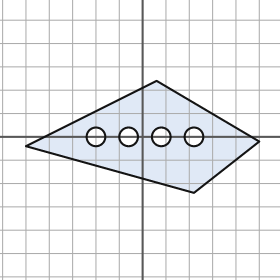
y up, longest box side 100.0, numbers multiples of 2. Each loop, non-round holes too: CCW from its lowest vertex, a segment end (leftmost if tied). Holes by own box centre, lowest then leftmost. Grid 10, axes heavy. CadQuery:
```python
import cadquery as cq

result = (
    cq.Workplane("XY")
    .moveTo(22.0, -24.0)
    .lineTo(50.0, -2.0)
    .lineTo(6.0, 24.0)
    .lineTo(-50.0, -4.0)
    .close()
    .moveTo(-20.0, 0.0)
    .circle(4.0)
    .moveTo(-6.0, 0.0)
    .circle(4.0)
    .moveTo(8.0, 0.0)
    .circle(4.0)
    .moveTo(22.0, 0.0)
    .circle(4.0)
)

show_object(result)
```